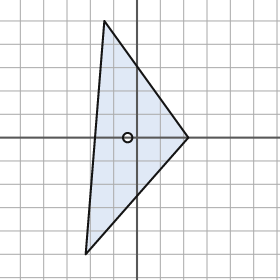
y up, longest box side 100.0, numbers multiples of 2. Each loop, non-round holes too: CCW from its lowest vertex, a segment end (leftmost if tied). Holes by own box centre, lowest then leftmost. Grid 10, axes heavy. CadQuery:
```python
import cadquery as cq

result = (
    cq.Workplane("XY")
    .moveTo(-22.0, -50.0)
    .lineTo(22.0, 0.0)
    .lineTo(-14.0, 50.0)
    .close()
    .moveTo(-4.0, 0.0)
    .circle(2.0)
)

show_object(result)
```